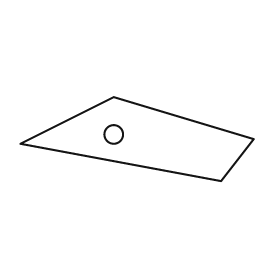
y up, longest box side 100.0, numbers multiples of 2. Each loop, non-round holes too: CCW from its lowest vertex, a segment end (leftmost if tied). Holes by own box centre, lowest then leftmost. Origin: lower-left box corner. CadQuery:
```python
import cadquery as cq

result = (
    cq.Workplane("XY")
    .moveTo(86.0, 0.0)
    .lineTo(100.0, 18.0)
    .lineTo(40.0, 36.0)
    .lineTo(0.0, 16.0)
    .close()
    .moveTo(40.0, 20.0)
    .circle(4.0)
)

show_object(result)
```